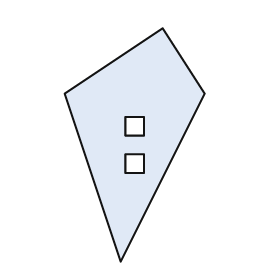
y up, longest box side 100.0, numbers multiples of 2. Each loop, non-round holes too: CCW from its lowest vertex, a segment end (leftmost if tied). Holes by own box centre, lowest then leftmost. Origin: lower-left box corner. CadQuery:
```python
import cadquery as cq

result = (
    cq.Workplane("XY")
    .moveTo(24.0, 0.0)
    .lineTo(60.0, 72.0)
    .lineTo(42.0, 100.0)
    .lineTo(0.0, 72.0)
    .close()
    .moveTo(26.0, 38.0)
    .lineTo(34.0, 38.0)
    .lineTo(34.0, 46.0)
    .lineTo(26.0, 46.0)
    .close()
    .moveTo(26.0, 54.0)
    .lineTo(34.0, 54.0)
    .lineTo(34.0, 62.0)
    .lineTo(26.0, 62.0)
    .close()
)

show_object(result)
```